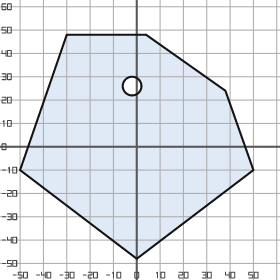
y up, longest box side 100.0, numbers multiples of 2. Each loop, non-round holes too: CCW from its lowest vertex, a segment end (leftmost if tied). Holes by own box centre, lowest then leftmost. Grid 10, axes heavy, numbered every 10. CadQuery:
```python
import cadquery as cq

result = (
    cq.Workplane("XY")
    .moveTo(0.0, -48.0)
    .lineTo(50.0, -10.0)
    .lineTo(38.0, 24.0)
    .lineTo(4.0, 48.0)
    .lineTo(-30.0, 48.0)
    .lineTo(-50.0, -10.0)
    .close()
    .moveTo(-2.0, 26.0)
    .circle(4.0)
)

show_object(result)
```